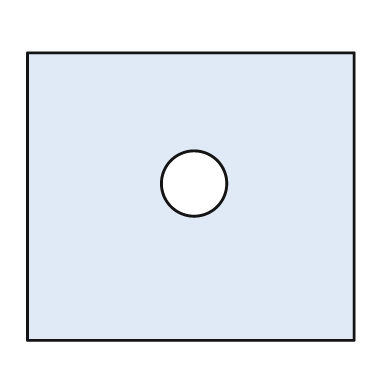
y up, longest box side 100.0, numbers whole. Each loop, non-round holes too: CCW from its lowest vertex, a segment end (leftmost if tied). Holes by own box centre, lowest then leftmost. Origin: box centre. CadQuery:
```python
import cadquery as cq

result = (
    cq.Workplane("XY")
    .moveTo(-50.0, -44.0)
    .lineTo(50.0, -44.0)
    .lineTo(50.0, 44.0)
    .lineTo(-50.0, 44.0)
    .close()
    .moveTo(1.0, 4.0)
    .circle(10.0)
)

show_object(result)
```